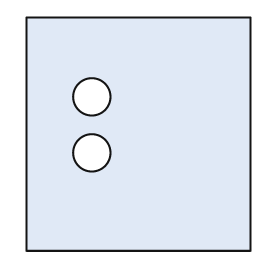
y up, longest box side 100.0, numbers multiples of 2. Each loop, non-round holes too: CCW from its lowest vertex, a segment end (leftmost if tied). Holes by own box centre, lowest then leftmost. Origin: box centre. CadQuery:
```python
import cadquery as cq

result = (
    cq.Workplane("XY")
    .moveTo(-48.0, -50.0)
    .lineTo(48.0, -50.0)
    .lineTo(48.0, 50.0)
    .lineTo(-48.0, 50.0)
    .close()
    .moveTo(-20.0, -8.0)
    .circle(8.0)
    .moveTo(-20.0, 16.0)
    .circle(8.0)
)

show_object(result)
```